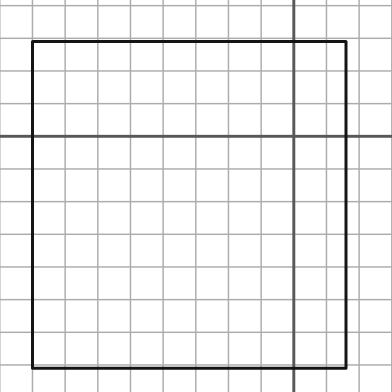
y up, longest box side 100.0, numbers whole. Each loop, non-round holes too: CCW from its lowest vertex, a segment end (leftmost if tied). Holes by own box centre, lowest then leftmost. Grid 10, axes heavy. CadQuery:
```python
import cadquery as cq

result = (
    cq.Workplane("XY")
    .moveTo(-80.0, -71.0)
    .lineTo(16.0, -71.0)
    .lineTo(16.0, 29.0)
    .lineTo(-80.0, 29.0)
    .close()
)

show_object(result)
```